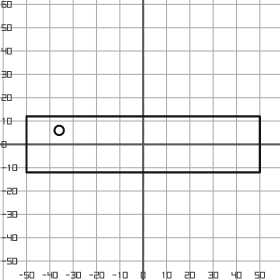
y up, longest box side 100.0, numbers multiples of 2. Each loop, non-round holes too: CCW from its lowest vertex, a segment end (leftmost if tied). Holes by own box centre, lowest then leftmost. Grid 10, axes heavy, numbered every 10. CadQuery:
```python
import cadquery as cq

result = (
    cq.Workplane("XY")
    .moveTo(-50.0, -12.0)
    .lineTo(50.0, -12.0)
    .lineTo(50.0, 12.0)
    .lineTo(-50.0, 12.0)
    .close()
    .moveTo(-36.0, 6.0)
    .circle(2.0)
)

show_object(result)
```